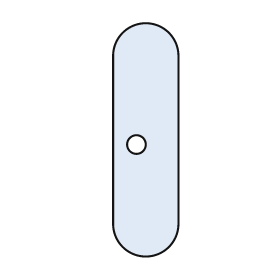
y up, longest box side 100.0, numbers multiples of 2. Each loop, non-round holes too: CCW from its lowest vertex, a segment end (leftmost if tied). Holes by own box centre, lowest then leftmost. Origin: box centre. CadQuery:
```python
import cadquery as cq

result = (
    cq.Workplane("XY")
    .moveTo(-14.0, -36.0)
    .threePointArc((0.0, -50.0), (14.0, -36.0))
    .lineTo(14.0, 36.0)
    .threePointArc((0.0, 50.0), (-14.0, 36.0))
    .close()
    .moveTo(-4.0, -2.0)
    .circle(4.0)
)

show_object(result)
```